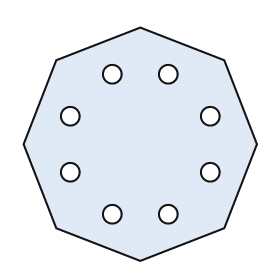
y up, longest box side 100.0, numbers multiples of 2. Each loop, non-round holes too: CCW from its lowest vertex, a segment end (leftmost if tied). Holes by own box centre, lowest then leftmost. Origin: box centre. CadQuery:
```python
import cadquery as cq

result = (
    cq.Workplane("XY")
    .moveTo(0.0, -50.0)
    .lineTo(36.0, -36.0)
    .lineTo(50.0, 0.0)
    .lineTo(36.0, 36.0)
    .lineTo(0.0, 50.0)
    .lineTo(-36.0, 36.0)
    .lineTo(-50.0, 0.0)
    .lineTo(-36.0, -36.0)
    .close()
    .moveTo(-12.0, -30.0)
    .circle(4.0)
    .moveTo(12.0, -30.0)
    .circle(4.0)
    .moveTo(-30.0, -12.0)
    .circle(4.0)
    .moveTo(30.0, -12.0)
    .circle(4.0)
    .moveTo(-30.0, 12.0)
    .circle(4.0)
    .moveTo(30.0, 12.0)
    .circle(4.0)
    .moveTo(-12.0, 30.0)
    .circle(4.0)
    .moveTo(12.0, 30.0)
    .circle(4.0)
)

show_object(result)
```